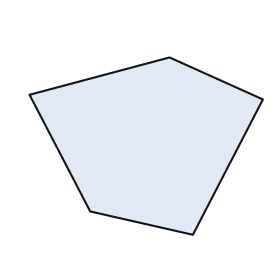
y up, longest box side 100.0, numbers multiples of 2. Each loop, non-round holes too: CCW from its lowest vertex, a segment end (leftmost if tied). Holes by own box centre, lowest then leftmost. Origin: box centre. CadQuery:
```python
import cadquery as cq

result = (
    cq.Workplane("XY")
    .moveTo(20.0, -38.0)
    .lineTo(50.0, 20.0)
    .lineTo(10.0, 38.0)
    .lineTo(-50.0, 22.0)
    .lineTo(-24.0, -28.0)
    .close()
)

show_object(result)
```